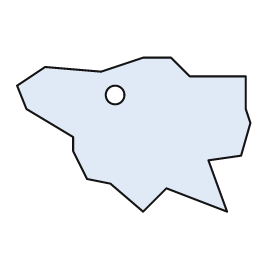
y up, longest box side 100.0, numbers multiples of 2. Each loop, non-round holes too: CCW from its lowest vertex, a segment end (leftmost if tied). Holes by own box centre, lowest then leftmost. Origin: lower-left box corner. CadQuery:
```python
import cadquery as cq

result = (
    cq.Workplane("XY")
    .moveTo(54.0, 0.0)
    .lineTo(64.0, 10.0)
    .lineTo(90.0, 0.0)
    .lineTo(82.0, 22.0)
    .lineTo(96.0, 24.0)
    .lineTo(100.0, 38.0)
    .lineTo(98.0, 44.0)
    .lineTo(98.0, 58.0)
    .lineTo(74.0, 58.0)
    .lineTo(66.0, 66.0)
    .lineTo(54.0, 66.0)
    .lineTo(36.0, 60.0)
    .lineTo(12.0, 62.0)
    .lineTo(0.0, 54.0)
    .lineTo(4.0, 44.0)
    .lineTo(24.0, 32.0)
    .lineTo(24.0, 26.0)
    .lineTo(30.0, 14.0)
    .lineTo(40.0, 12.0)
    .close()
    .moveTo(42.0, 50.0)
    .circle(4.0)
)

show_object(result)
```